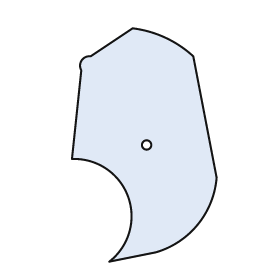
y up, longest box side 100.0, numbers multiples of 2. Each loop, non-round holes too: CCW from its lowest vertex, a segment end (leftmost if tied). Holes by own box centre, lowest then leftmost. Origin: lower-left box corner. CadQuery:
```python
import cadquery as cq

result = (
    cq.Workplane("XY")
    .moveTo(16.0, 0.0)
    .lineTo(36.0, 4.0)
    .threePointArc((54.0, 16.0), (62.0, 36.0))
    .lineTo(52.0, 88.0)
    .threePointArc((40.0, 96.0), (26.0, 100.0))
    .lineTo(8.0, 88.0)
    .threePointArc((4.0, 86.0), (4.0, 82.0))
    .lineTo(0.0, 44.0)
    .threePointArc((24.0, 28.0), (16.0, 0.0))
    .close()
    .moveTo(32.0, 50.0)
    .circle(2.0)
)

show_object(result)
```